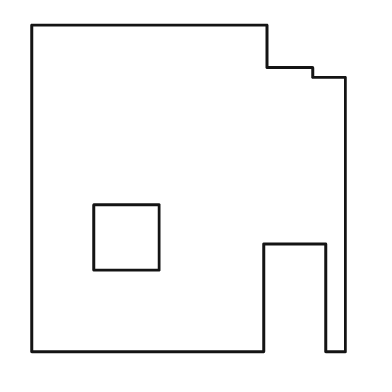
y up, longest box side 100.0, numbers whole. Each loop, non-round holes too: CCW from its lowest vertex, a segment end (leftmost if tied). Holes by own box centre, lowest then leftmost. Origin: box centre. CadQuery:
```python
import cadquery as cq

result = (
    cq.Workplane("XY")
    .moveTo(-48.0, -50.0)
    .lineTo(23.0, -50.0)
    .lineTo(23.0, -17.0)
    .lineTo(42.0, -17.0)
    .lineTo(42.0, -50.0)
    .lineTo(48.0, -50.0)
    .lineTo(48.0, 34.0)
    .lineTo(38.0, 34.0)
    .lineTo(38.0, 37.0)
    .lineTo(24.0, 37.0)
    .lineTo(24.0, 50.0)
    .lineTo(-48.0, 50.0)
    .close()
    .moveTo(-29.0, -25.0)
    .lineTo(-9.0, -25.0)
    .lineTo(-9.0, -5.0)
    .lineTo(-29.0, -5.0)
    .close()
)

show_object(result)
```